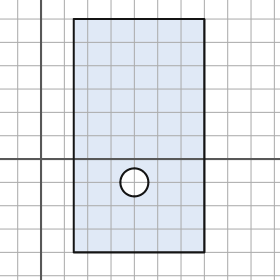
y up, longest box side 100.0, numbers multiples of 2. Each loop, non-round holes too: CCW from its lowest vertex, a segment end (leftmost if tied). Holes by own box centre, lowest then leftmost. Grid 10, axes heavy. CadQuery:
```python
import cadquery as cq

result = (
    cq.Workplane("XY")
    .moveTo(14.0, -40.0)
    .lineTo(70.0, -40.0)
    .lineTo(70.0, 60.0)
    .lineTo(14.0, 60.0)
    .close()
    .moveTo(40.0, -10.0)
    .circle(6.0)
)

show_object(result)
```